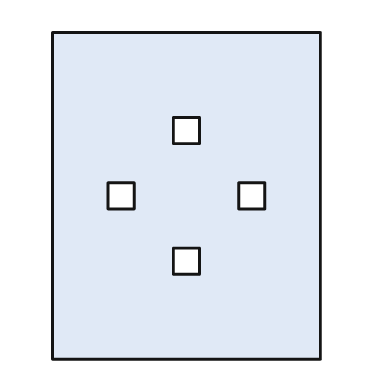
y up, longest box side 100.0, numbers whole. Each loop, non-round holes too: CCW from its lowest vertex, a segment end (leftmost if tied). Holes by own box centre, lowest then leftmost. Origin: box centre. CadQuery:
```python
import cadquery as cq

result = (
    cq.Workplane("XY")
    .moveTo(-41.0, -50.0)
    .lineTo(41.0, -50.0)
    .lineTo(41.0, 50.0)
    .lineTo(-41.0, 50.0)
    .close()
    .moveTo(-4.0, -24.0)
    .lineTo(4.0, -24.0)
    .lineTo(4.0, -16.0)
    .lineTo(-4.0, -16.0)
    .close()
    .moveTo(-24.0, -4.0)
    .lineTo(-16.0, -4.0)
    .lineTo(-16.0, 4.0)
    .lineTo(-24.0, 4.0)
    .close()
    .moveTo(16.0, -4.0)
    .lineTo(24.0, -4.0)
    .lineTo(24.0, 4.0)
    .lineTo(16.0, 4.0)
    .close()
    .moveTo(-4.0, 16.0)
    .lineTo(4.0, 16.0)
    .lineTo(4.0, 24.0)
    .lineTo(-4.0, 24.0)
    .close()
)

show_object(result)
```